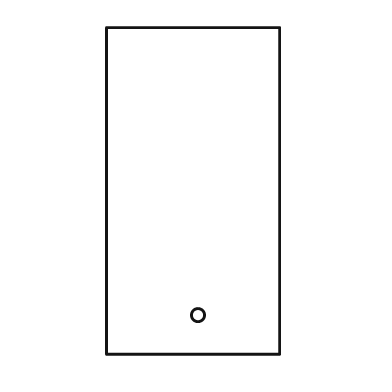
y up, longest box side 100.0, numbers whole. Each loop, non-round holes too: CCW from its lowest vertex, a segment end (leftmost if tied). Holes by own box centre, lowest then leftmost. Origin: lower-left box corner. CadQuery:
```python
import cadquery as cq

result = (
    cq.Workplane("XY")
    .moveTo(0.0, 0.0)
    .lineTo(53.0, 0.0)
    .lineTo(53.0, 100.0)
    .lineTo(0.0, 100.0)
    .close()
    .moveTo(28.0, 12.0)
    .circle(2.0)
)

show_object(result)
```